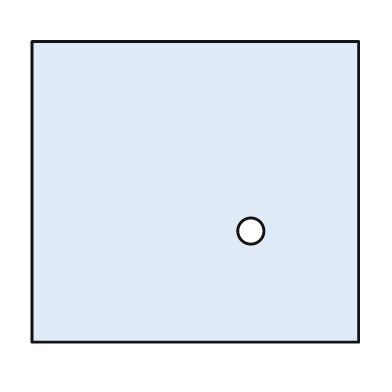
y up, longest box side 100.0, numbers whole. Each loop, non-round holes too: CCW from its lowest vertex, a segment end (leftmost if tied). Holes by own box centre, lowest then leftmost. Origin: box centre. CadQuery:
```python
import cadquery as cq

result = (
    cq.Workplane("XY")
    .moveTo(-50.0, -46.0)
    .lineTo(50.0, -46.0)
    .lineTo(50.0, 46.0)
    .lineTo(-50.0, 46.0)
    .close()
    .moveTo(17.0, -12.0)
    .circle(4.0)
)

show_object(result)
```